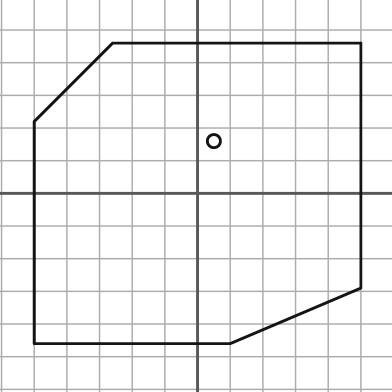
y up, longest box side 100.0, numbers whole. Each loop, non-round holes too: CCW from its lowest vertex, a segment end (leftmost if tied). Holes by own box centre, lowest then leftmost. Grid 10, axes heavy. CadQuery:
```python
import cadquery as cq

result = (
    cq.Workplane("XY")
    .moveTo(-50.0, -46.0)
    .lineTo(10.0, -46.0)
    .lineTo(50.0, -29.0)
    .lineTo(50.0, 46.0)
    .lineTo(-26.0, 46.0)
    .lineTo(-50.0, 22.0)
    .close()
    .moveTo(5.0, 16.0)
    .circle(2.0)
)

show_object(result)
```